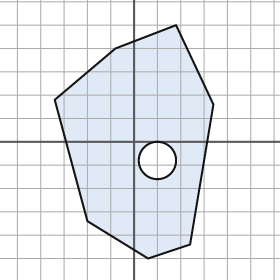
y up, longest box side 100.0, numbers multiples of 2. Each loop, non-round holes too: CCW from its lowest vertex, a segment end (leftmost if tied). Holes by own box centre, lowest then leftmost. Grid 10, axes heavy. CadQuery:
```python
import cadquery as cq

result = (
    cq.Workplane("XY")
    .moveTo(6.0, -50.0)
    .lineTo(24.0, -44.0)
    .lineTo(34.0, 16.0)
    .lineTo(18.0, 50.0)
    .lineTo(-8.0, 40.0)
    .lineTo(-34.0, 18.0)
    .lineTo(-20.0, -34.0)
    .close()
    .moveTo(10.0, -8.0)
    .circle(8.0)
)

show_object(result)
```